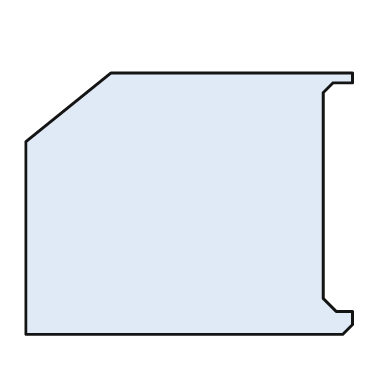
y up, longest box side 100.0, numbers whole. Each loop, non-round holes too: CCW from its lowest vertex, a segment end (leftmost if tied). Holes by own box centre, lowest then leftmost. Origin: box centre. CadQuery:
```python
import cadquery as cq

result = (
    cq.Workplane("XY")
    .moveTo(-50.0, -40.0)
    .lineTo(47.0, -40.0)
    .lineTo(50.0, -37.0)
    .lineTo(50.0, -33.0)
    .lineTo(45.0, -33.0)
    .lineTo(41.0, -29.0)
    .lineTo(41.0, 34.0)
    .lineTo(44.0, 37.0)
    .lineTo(50.0, 37.0)
    .lineTo(50.0, 40.0)
    .lineTo(-24.0, 40.0)
    .lineTo(-50.0, 19.0)
    .close()
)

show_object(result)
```